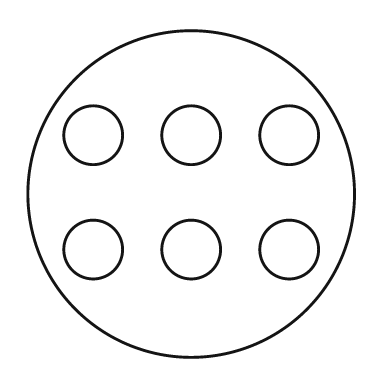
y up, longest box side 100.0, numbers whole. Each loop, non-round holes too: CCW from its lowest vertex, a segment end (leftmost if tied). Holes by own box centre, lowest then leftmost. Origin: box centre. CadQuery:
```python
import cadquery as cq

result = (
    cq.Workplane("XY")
    .moveTo(0.0, 0.0)
    .circle(50.0)
    .moveTo(-30.0, -17.0)
    .circle(9.0)
    .moveTo(0.0, -17.0)
    .circle(9.0)
    .moveTo(30.0, -17.0)
    .circle(9.0)
    .moveTo(-30.0, 18.0)
    .circle(9.0)
    .moveTo(0.0, 18.0)
    .circle(9.0)
    .moveTo(30.0, 18.0)
    .circle(9.0)
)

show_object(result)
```